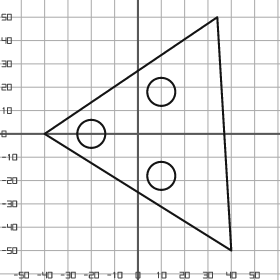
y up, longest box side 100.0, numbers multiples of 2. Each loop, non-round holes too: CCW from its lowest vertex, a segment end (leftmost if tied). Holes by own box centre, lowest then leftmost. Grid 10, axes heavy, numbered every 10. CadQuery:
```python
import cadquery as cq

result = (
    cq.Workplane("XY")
    .moveTo(40.0, -50.0)
    .lineTo(34.0, 50.0)
    .lineTo(-40.0, 0.0)
    .close()
    .moveTo(10.0, -18.0)
    .circle(6.0)
    .moveTo(-20.0, 0.0)
    .circle(6.0)
    .moveTo(10.0, 18.0)
    .circle(6.0)
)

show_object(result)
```